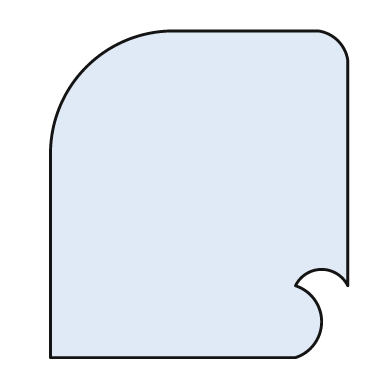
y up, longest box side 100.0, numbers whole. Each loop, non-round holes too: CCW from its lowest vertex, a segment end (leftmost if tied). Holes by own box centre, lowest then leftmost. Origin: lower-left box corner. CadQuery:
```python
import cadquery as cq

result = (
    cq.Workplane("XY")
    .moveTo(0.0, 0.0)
    .lineTo(75.0, 0.0)
    .threePointArc((83.0, 11.0), (75.0, 22.0))
    .threePointArc((83.0, 27.0), (91.0, 22.0))
    .lineTo(91.0, 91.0)
    .threePointArc((88.0, 97.0), (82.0, 100.0))
    .lineTo(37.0, 100.0)
    .threePointArc((11.0, 89.0), (0.0, 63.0))
    .close()
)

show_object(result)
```